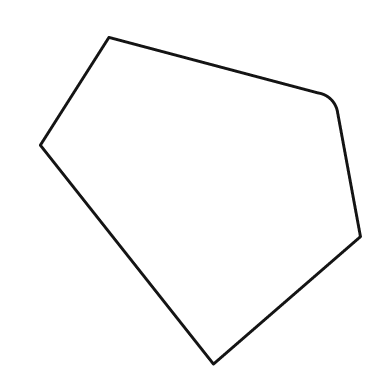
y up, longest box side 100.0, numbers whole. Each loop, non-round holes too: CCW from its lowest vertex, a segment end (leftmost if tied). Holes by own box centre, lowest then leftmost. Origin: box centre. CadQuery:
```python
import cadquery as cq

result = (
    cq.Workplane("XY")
    .moveTo(4.0, -50.0)
    .lineTo(49.0, -11.0)
    .lineTo(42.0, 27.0)
    .threePointArc((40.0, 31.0), (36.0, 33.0))
    .lineTo(-28.0, 50.0)
    .lineTo(-49.0, 17.0)
    .close()
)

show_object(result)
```